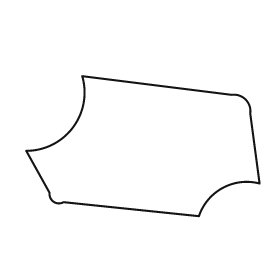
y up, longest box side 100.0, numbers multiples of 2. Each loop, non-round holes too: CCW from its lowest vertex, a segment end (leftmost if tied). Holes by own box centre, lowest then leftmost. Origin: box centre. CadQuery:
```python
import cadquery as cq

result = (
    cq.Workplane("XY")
    .moveTo(24.0, -30.0)
    .threePointArc((34.0, -18.0), (50.0, -16.0))
    .lineTo(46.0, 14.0)
    .threePointArc((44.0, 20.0), (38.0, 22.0))
    .lineTo(-26.0, 30.0)
    .threePointArc((-30.0, 8.0), (-50.0, -2.0))
    .lineTo(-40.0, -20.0)
    .threePointArc((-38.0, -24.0), (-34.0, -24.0))
    .close()
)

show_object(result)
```